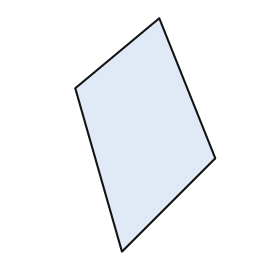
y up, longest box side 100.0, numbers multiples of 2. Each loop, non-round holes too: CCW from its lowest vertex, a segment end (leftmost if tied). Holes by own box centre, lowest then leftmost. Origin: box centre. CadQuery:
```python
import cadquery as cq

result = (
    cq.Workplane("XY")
    .moveTo(-10.0, -50.0)
    .lineTo(30.0, -10.0)
    .lineTo(6.0, 50.0)
    .lineTo(-30.0, 20.0)
    .close()
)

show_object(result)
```